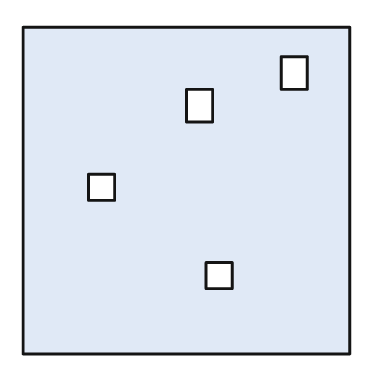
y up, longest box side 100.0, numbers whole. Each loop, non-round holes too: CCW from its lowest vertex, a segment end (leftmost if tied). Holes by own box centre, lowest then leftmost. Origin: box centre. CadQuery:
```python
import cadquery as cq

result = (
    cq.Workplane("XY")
    .moveTo(-50.0, -50.0)
    .lineTo(50.0, -50.0)
    .lineTo(50.0, 50.0)
    .lineTo(-50.0, 50.0)
    .close()
    .moveTo(6.0, -30.0)
    .lineTo(14.0, -30.0)
    .lineTo(14.0, -22.0)
    .lineTo(6.0, -22.0)
    .close()
    .moveTo(-30.0, -3.0)
    .lineTo(-22.0, -3.0)
    .lineTo(-22.0, 5.0)
    .lineTo(-30.0, 5.0)
    .close()
    .moveTo(0.0, 21.0)
    .lineTo(8.0, 21.0)
    .lineTo(8.0, 31.0)
    .lineTo(0.0, 31.0)
    .close()
    .moveTo(29.0, 31.0)
    .lineTo(37.0, 31.0)
    .lineTo(37.0, 41.0)
    .lineTo(29.0, 41.0)
    .close()
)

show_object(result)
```